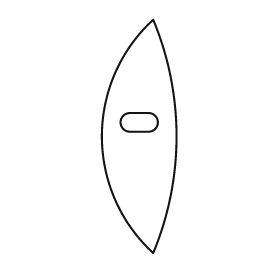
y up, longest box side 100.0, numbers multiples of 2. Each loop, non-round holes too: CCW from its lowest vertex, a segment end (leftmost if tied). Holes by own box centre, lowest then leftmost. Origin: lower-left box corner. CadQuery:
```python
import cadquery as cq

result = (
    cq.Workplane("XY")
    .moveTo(22.0, 0.0)
    .threePointArc((32.0, 50.0), (22.0, 100.0))
    .threePointArc((0.0, 50.0), (22.0, 0.0))
    .close()
    .moveTo(12.0, 52.0)
    .lineTo(20.0, 52.0)
    .threePointArc((24.0, 56.0), (20.0, 60.0))
    .lineTo(12.0, 60.0)
    .threePointArc((8.0, 56.0), (12.0, 52.0))
    .close()
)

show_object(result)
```